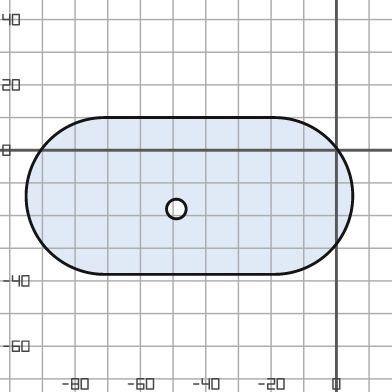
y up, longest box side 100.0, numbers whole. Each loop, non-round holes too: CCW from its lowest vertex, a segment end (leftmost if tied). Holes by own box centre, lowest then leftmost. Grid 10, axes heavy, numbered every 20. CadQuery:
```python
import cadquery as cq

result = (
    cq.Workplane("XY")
    .moveTo(-71.0, -38.0)
    .lineTo(-19.0, -38.0)
    .threePointArc((5.0, -14.0), (-19.0, 10.0))
    .lineTo(-71.0, 10.0)
    .threePointArc((-95.0, -14.0), (-71.0, -38.0))
    .close()
    .moveTo(-49.0, -18.0)
    .circle(3.0)
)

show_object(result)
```